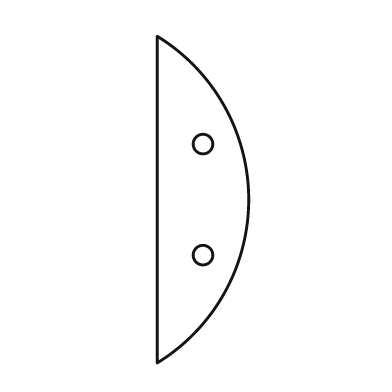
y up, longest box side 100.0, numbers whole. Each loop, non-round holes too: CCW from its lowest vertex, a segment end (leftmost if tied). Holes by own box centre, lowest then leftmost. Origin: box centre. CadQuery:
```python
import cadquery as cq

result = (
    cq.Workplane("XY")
    .moveTo(-14.0, -50.0)
    .threePointArc((14.0, 0.0), (-14.0, 50.0))
    .close()
    .moveTo(0.0, -17.0)
    .circle(3.0)
    .moveTo(0.0, 17.0)
    .circle(3.0)
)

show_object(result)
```